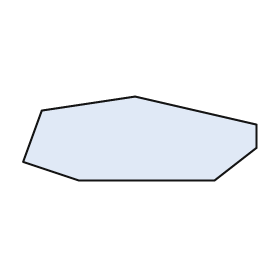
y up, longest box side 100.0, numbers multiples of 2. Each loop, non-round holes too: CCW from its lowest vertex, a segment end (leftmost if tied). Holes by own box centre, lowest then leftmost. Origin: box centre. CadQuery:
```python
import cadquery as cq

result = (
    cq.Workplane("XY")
    .moveTo(-26.0, -18.0)
    .lineTo(32.0, -18.0)
    .lineTo(50.0, -4.0)
    .lineTo(50.0, 6.0)
    .lineTo(-2.0, 18.0)
    .lineTo(-42.0, 12.0)
    .lineTo(-50.0, -10.0)
    .close()
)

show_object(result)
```